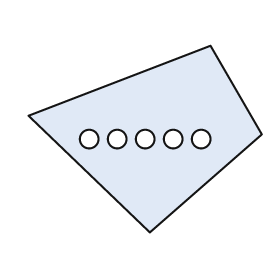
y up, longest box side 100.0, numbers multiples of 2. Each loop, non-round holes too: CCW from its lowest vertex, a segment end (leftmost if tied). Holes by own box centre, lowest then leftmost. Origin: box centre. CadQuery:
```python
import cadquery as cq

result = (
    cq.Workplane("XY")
    .moveTo(2.0, -40.0)
    .lineTo(50.0, 2.0)
    .lineTo(28.0, 40.0)
    .lineTo(-50.0, 10.0)
    .close()
    .moveTo(-24.0, 0.0)
    .circle(4.0)
    .moveTo(-12.0, 0.0)
    .circle(4.0)
    .moveTo(0.0, 0.0)
    .circle(4.0)
    .moveTo(12.0, 0.0)
    .circle(4.0)
    .moveTo(24.0, 0.0)
    .circle(4.0)
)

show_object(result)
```